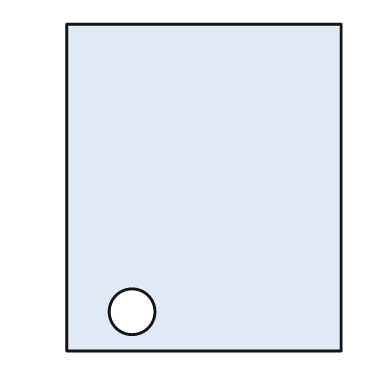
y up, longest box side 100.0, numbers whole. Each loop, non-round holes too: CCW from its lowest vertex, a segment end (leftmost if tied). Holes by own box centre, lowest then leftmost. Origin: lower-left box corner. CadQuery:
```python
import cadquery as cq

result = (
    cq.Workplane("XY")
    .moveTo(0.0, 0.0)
    .lineTo(84.0, 0.0)
    .lineTo(84.0, 100.0)
    .lineTo(0.0, 100.0)
    .close()
    .moveTo(20.0, 12.0)
    .circle(7.0)
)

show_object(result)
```